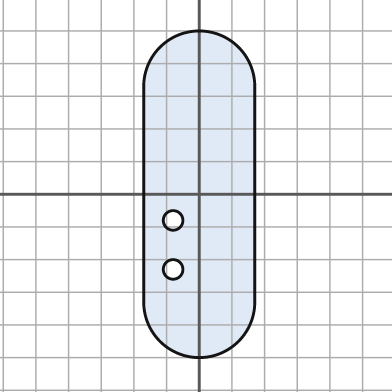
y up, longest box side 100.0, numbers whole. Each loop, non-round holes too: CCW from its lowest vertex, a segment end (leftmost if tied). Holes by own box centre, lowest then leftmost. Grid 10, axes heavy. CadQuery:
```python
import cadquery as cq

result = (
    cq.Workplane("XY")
    .moveTo(-17.0, -33.0)
    .threePointArc((0.0, -50.0), (17.0, -33.0))
    .lineTo(17.0, 33.0)
    .threePointArc((0.0, 50.0), (-17.0, 33.0))
    .close()
    .moveTo(-8.0, -23.0)
    .circle(3.0)
    .moveTo(-8.0, -8.0)
    .circle(3.0)
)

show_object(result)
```